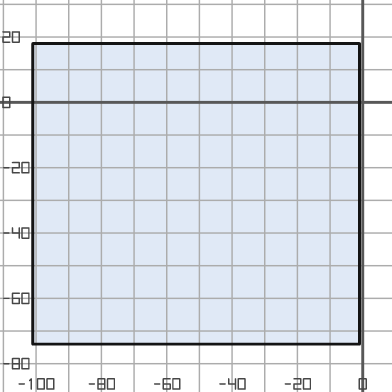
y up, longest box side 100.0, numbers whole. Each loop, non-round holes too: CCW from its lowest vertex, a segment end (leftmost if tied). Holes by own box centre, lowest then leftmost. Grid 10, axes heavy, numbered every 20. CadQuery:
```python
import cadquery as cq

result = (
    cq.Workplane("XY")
    .moveTo(-101.0, -74.0)
    .lineTo(-1.0, -74.0)
    .lineTo(-1.0, 18.0)
    .lineTo(-101.0, 18.0)
    .close()
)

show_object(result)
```